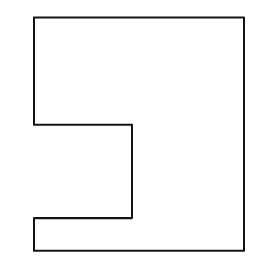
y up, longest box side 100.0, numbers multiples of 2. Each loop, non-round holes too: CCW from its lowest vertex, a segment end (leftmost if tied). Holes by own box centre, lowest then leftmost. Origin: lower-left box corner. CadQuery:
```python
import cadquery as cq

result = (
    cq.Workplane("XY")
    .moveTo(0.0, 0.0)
    .lineTo(90.0, 0.0)
    .lineTo(90.0, 100.0)
    .lineTo(0.0, 100.0)
    .lineTo(0.0, 54.0)
    .lineTo(42.0, 54.0)
    .lineTo(42.0, 14.0)
    .lineTo(0.0, 14.0)
    .close()
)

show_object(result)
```